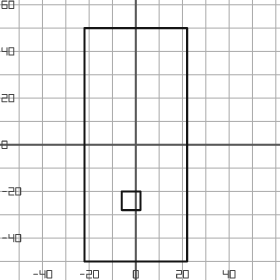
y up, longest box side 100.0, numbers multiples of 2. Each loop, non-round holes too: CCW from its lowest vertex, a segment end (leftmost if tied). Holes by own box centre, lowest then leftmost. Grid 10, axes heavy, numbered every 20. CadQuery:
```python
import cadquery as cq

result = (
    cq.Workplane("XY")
    .moveTo(-22.0, -50.0)
    .lineTo(22.0, -50.0)
    .lineTo(22.0, 50.0)
    .lineTo(-22.0, 50.0)
    .close()
    .moveTo(-6.0, -28.0)
    .lineTo(2.0, -28.0)
    .lineTo(2.0, -20.0)
    .lineTo(-6.0, -20.0)
    .close()
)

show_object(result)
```